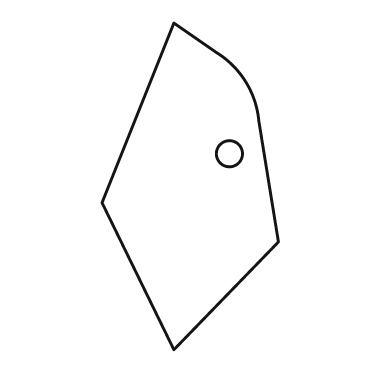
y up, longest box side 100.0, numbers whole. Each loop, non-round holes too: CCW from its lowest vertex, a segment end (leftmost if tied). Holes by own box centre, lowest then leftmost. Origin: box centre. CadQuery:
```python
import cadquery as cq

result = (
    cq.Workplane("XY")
    .moveTo(-5.0, -50.0)
    .lineTo(27.0, -17.0)
    .lineTo(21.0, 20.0)
    .threePointArc((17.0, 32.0), (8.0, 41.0))
    .lineTo(-5.0, 50.0)
    .lineTo(-27.0, -5.0)
    .close()
    .moveTo(12.0, 10.0)
    .circle(4.0)
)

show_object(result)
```